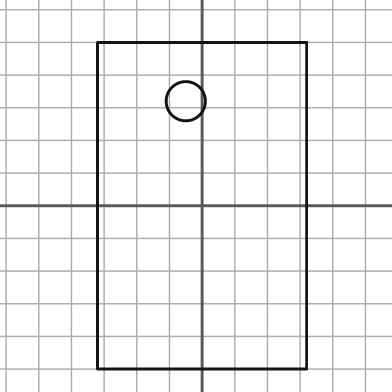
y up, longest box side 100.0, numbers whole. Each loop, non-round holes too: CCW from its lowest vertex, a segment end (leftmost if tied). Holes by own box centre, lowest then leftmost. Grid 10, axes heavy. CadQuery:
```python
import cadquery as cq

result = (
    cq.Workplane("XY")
    .moveTo(-32.0, -50.0)
    .lineTo(32.0, -50.0)
    .lineTo(32.0, 50.0)
    .lineTo(-32.0, 50.0)
    .close()
    .moveTo(-5.0, 32.0)
    .circle(6.0)
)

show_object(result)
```